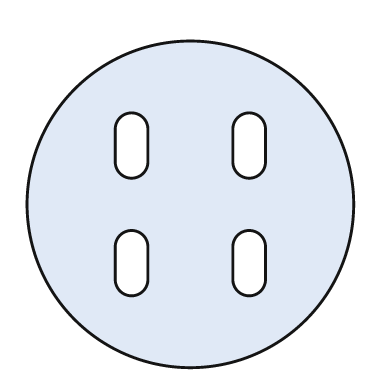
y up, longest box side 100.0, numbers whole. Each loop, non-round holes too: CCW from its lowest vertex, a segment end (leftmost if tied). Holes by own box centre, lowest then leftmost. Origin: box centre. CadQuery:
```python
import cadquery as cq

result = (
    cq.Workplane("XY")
    .moveTo(0.0, 0.0)
    .circle(50.0)
    .moveTo(-23.0, -23.0)
    .threePointArc((-18.0, -28.0), (-13.0, -23.0))
    .lineTo(-13.0, -13.0)
    .threePointArc((-18.0, -8.0), (-23.0, -13.0))
    .close()
    .moveTo(13.0, -23.0)
    .threePointArc((18.0, -28.0), (23.0, -23.0))
    .lineTo(23.0, -13.0)
    .threePointArc((18.0, -8.0), (13.0, -13.0))
    .close()
    .moveTo(-23.0, 13.0)
    .threePointArc((-18.0, 8.0), (-13.0, 13.0))
    .lineTo(-13.0, 23.0)
    .threePointArc((-18.0, 28.0), (-23.0, 23.0))
    .close()
    .moveTo(13.0, 13.0)
    .threePointArc((18.0, 8.0), (23.0, 13.0))
    .lineTo(23.0, 23.0)
    .threePointArc((18.0, 28.0), (13.0, 23.0))
    .close()
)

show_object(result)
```